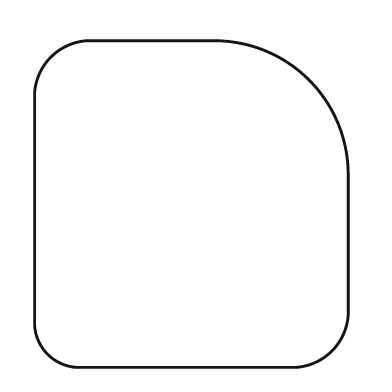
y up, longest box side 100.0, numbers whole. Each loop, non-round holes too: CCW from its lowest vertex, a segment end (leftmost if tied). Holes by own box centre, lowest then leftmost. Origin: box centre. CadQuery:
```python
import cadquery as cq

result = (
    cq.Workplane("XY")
    .moveTo(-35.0, -50.0)
    .lineTo(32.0, -50.0)
    .threePointArc((43.0, -45.0), (48.0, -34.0))
    .lineTo(48.0, 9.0)
    .threePointArc((36.0, 38.0), (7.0, 50.0))
    .lineTo(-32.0, 50.0)
    .threePointArc((-43.0, 45.0), (-48.0, 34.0))
    .lineTo(-48.0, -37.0)
    .threePointArc((-44.0, -46.0), (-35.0, -50.0))
    .close()
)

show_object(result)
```